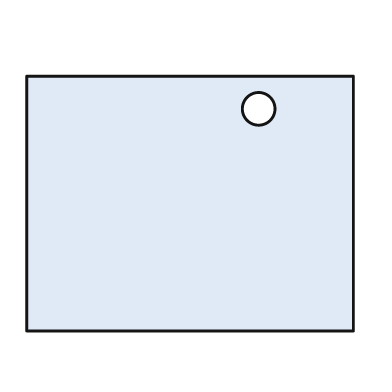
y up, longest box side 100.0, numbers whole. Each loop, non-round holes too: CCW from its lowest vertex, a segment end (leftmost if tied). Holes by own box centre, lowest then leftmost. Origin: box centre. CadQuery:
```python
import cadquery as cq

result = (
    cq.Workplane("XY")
    .moveTo(-50.0, -39.0)
    .lineTo(50.0, -39.0)
    .lineTo(50.0, 39.0)
    .lineTo(-50.0, 39.0)
    .close()
    .moveTo(21.0, 29.0)
    .circle(5.0)
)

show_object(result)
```